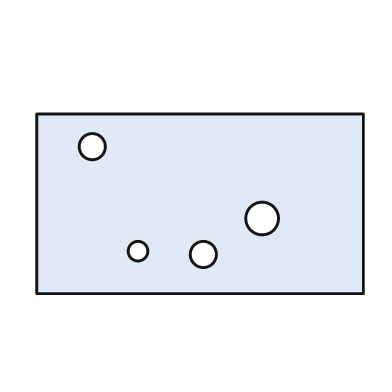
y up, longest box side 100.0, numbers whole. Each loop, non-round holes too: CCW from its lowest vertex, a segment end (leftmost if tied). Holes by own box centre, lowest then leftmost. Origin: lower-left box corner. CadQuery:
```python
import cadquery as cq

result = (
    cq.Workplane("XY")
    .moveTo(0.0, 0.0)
    .lineTo(100.0, 0.0)
    .lineTo(100.0, 55.0)
    .lineTo(0.0, 55.0)
    .close()
    .moveTo(51.0, 12.0)
    .circle(4.0)
    .moveTo(31.0, 13.0)
    .circle(3.0)
    .moveTo(69.0, 23.0)
    .circle(5.0)
    .moveTo(17.0, 45.0)
    .circle(4.0)
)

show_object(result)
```